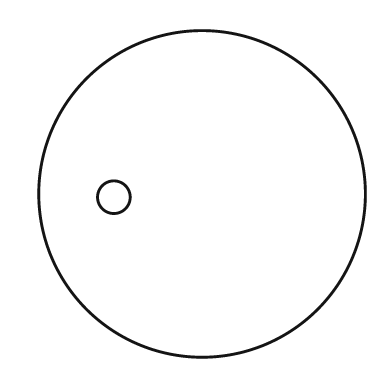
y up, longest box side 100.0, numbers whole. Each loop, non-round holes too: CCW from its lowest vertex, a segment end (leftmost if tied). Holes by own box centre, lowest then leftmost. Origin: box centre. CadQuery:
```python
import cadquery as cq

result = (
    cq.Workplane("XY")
    .moveTo(0.0, 0.0)
    .circle(50.0)
    .moveTo(-27.0, -1.0)
    .circle(5.0)
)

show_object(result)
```